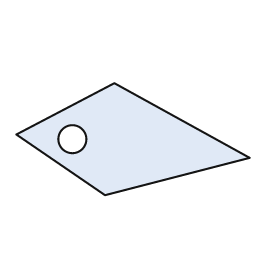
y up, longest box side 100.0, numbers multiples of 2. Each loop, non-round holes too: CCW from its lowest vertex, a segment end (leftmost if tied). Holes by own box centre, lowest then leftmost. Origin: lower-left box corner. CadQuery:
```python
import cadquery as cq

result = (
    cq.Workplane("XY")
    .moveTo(38.0, 0.0)
    .lineTo(100.0, 16.0)
    .lineTo(42.0, 48.0)
    .lineTo(0.0, 26.0)
    .close()
    .moveTo(24.0, 24.0)
    .circle(6.0)
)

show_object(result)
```